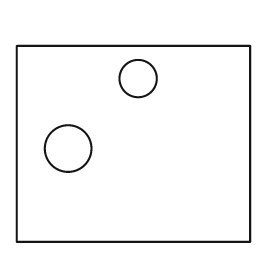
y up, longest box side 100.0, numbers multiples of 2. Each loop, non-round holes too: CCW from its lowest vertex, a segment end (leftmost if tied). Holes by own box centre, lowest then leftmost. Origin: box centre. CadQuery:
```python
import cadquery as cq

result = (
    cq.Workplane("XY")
    .moveTo(-50.0, -42.0)
    .lineTo(50.0, -42.0)
    .lineTo(50.0, 42.0)
    .lineTo(-50.0, 42.0)
    .close()
    .moveTo(-28.0, -2.0)
    .circle(10.0)
    .moveTo(2.0, 28.0)
    .circle(8.0)
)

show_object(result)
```